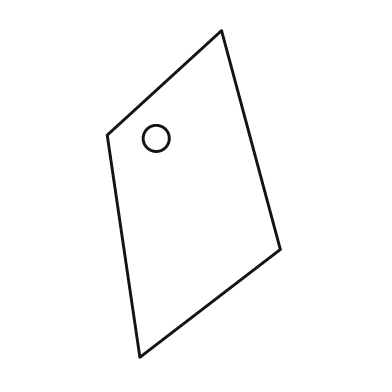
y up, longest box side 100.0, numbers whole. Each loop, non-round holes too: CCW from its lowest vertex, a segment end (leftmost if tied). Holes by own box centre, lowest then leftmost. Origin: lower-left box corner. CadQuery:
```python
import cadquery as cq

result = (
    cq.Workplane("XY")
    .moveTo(10.0, 0.0)
    .lineTo(53.0, 33.0)
    .lineTo(35.0, 100.0)
    .lineTo(0.0, 68.0)
    .close()
    .moveTo(15.0, 67.0)
    .circle(4.0)
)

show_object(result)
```